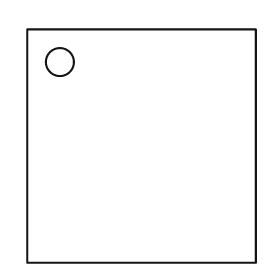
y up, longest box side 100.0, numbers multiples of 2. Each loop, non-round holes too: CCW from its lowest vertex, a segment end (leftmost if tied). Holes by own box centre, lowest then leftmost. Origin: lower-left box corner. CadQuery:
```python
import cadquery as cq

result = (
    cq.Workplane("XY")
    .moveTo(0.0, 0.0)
    .lineTo(98.0, 0.0)
    .lineTo(98.0, 100.0)
    .lineTo(0.0, 100.0)
    .close()
    .moveTo(14.0, 86.0)
    .circle(6.0)
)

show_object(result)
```